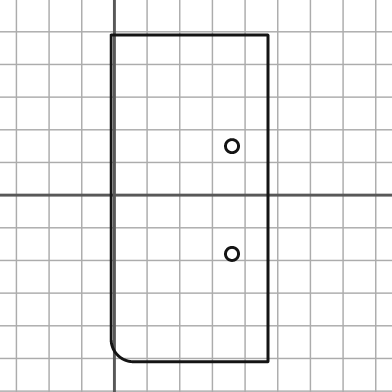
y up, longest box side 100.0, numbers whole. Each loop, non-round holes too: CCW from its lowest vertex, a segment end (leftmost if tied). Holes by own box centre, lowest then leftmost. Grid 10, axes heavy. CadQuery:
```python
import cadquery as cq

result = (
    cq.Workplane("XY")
    .moveTo(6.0, -51.0)
    .lineTo(47.0, -51.0)
    .lineTo(47.0, 49.0)
    .lineTo(-1.0, 49.0)
    .lineTo(-1.0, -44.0)
    .threePointArc((1.0, -49.0), (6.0, -51.0))
    .close()
    .moveTo(36.0, -18.0)
    .circle(2.0)
    .moveTo(36.0, 15.0)
    .circle(2.0)
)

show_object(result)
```